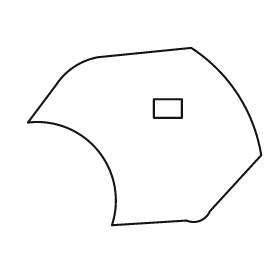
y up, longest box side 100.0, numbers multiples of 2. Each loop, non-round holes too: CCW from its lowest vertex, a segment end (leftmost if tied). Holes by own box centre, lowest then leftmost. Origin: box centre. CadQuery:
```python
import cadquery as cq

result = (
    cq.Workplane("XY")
    .moveTo(-14.0, -38.0)
    .lineTo(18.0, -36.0)
    .threePointArc((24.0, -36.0), (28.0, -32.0))
    .lineTo(50.0, -8.0)
    .threePointArc((40.0, 18.0), (20.0, 38.0))
    .lineTo(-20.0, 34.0)
    .threePointArc((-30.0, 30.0), (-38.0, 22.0))
    .lineTo(-50.0, 6.0)
    .threePointArc((-20.0, -6.0), (-14.0, -38.0))
    .close()
    .moveTo(4.0, 8.0)
    .lineTo(16.0, 8.0)
    .lineTo(16.0, 16.0)
    .lineTo(4.0, 16.0)
    .close()
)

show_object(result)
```